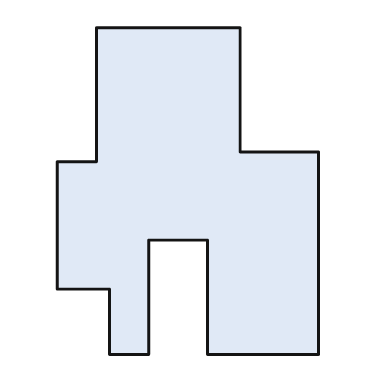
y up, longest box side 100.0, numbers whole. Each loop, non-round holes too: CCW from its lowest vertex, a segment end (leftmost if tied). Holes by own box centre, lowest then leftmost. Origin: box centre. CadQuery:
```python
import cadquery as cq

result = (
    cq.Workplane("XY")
    .moveTo(-24.0, -50.0)
    .lineTo(-12.0, -50.0)
    .lineTo(-12.0, -15.0)
    .lineTo(6.0, -15.0)
    .lineTo(6.0, -50.0)
    .lineTo(40.0, -50.0)
    .lineTo(40.0, 12.0)
    .lineTo(16.0, 12.0)
    .lineTo(16.0, 50.0)
    .lineTo(-28.0, 50.0)
    .lineTo(-28.0, 9.0)
    .lineTo(-40.0, 9.0)
    .lineTo(-40.0, -30.0)
    .lineTo(-24.0, -30.0)
    .close()
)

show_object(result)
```